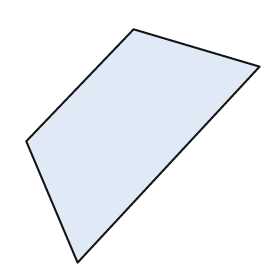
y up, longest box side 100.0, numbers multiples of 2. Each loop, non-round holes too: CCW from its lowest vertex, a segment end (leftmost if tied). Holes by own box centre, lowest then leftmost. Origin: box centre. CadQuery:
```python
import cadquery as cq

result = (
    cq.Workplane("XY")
    .moveTo(-28.0, -50.0)
    .lineTo(50.0, 34.0)
    .lineTo(-4.0, 50.0)
    .lineTo(-50.0, 2.0)
    .close()
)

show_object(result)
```